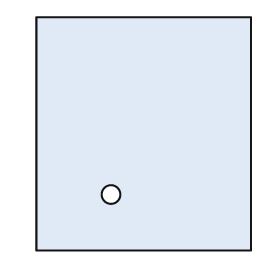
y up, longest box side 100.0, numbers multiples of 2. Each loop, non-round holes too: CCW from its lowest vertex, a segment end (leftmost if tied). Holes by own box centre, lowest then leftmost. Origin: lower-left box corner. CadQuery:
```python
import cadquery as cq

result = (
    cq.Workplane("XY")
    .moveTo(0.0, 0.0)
    .lineTo(92.0, 0.0)
    .lineTo(92.0, 100.0)
    .lineTo(0.0, 100.0)
    .close()
    .moveTo(32.0, 24.0)
    .circle(4.0)
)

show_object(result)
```